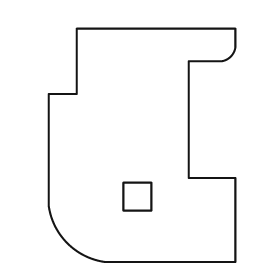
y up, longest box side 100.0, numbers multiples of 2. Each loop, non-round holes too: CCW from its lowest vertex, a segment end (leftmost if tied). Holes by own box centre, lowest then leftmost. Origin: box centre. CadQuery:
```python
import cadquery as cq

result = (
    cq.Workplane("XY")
    .moveTo(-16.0, -50.0)
    .lineTo(40.0, -50.0)
    .lineTo(40.0, -14.0)
    .lineTo(20.0, -14.0)
    .lineTo(20.0, 36.0)
    .lineTo(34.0, 36.0)
    .threePointArc((38.0, 38.0), (40.0, 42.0))
    .lineTo(40.0, 50.0)
    .lineTo(-28.0, 50.0)
    .lineTo(-28.0, 22.0)
    .lineTo(-40.0, 22.0)
    .lineTo(-40.0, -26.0)
    .threePointArc((-32.0, -42.0), (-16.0, -50.0))
    .close()
    .moveTo(-8.0, -28.0)
    .lineTo(4.0, -28.0)
    .lineTo(4.0, -16.0)
    .lineTo(-8.0, -16.0)
    .close()
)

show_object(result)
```